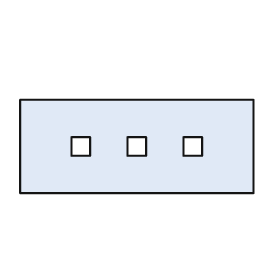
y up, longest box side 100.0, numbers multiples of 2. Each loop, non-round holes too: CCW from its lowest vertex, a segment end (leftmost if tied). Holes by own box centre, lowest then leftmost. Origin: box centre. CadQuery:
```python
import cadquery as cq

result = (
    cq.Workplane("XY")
    .moveTo(-50.0, -20.0)
    .lineTo(50.0, -20.0)
    .lineTo(50.0, 20.0)
    .lineTo(-50.0, 20.0)
    .close()
    .moveTo(-28.0, -4.0)
    .lineTo(-20.0, -4.0)
    .lineTo(-20.0, 4.0)
    .lineTo(-28.0, 4.0)
    .close()
    .moveTo(-4.0, -4.0)
    .lineTo(4.0, -4.0)
    .lineTo(4.0, 4.0)
    .lineTo(-4.0, 4.0)
    .close()
    .moveTo(20.0, -4.0)
    .lineTo(28.0, -4.0)
    .lineTo(28.0, 4.0)
    .lineTo(20.0, 4.0)
    .close()
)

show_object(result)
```